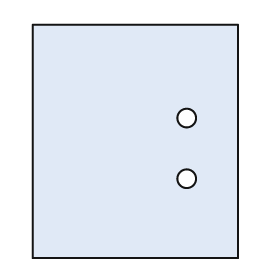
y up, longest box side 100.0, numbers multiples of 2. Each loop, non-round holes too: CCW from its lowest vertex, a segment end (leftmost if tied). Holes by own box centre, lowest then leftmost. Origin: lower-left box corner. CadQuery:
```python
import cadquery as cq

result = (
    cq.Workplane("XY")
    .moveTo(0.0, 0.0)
    .lineTo(88.0, 0.0)
    .lineTo(88.0, 100.0)
    .lineTo(0.0, 100.0)
    .close()
    .moveTo(66.0, 34.0)
    .circle(4.0)
    .moveTo(66.0, 60.0)
    .circle(4.0)
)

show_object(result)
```